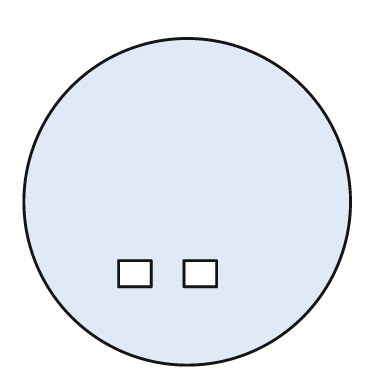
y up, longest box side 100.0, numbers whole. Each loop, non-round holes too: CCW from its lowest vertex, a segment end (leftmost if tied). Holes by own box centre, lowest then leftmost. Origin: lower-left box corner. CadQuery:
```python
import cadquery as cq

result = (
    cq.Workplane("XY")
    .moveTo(50.0, 50.0)
    .circle(50.0)
    .moveTo(29.0, 24.0)
    .lineTo(39.0, 24.0)
    .lineTo(39.0, 32.0)
    .lineTo(29.0, 32.0)
    .close()
    .moveTo(49.0, 24.0)
    .lineTo(59.0, 24.0)
    .lineTo(59.0, 32.0)
    .lineTo(49.0, 32.0)
    .close()
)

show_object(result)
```